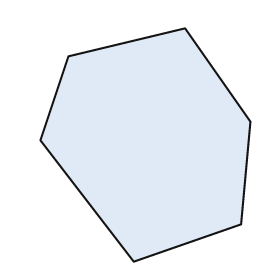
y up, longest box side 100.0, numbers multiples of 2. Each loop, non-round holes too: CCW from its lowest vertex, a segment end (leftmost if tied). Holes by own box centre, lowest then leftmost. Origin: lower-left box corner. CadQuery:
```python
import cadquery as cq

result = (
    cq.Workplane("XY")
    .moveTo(40.0, 0.0)
    .lineTo(86.0, 16.0)
    .lineTo(90.0, 60.0)
    .lineTo(62.0, 100.0)
    .lineTo(12.0, 88.0)
    .lineTo(0.0, 52.0)
    .close()
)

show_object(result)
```